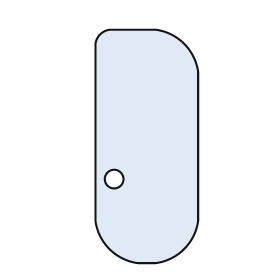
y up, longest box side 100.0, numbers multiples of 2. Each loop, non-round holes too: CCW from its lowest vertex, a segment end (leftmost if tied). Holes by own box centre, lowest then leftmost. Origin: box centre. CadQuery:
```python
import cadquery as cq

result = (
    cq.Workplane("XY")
    .moveTo(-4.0, -50.0)
    .lineTo(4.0, -50.0)
    .threePointArc((16.0, -44.0), (22.0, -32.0))
    .lineTo(22.0, 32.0)
    .threePointArc((16.0, 44.0), (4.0, 50.0))
    .lineTo(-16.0, 50.0)
    .threePointArc((-20.0, 48.0), (-22.0, 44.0))
    .lineTo(-22.0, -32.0)
    .threePointArc((-16.0, -44.0), (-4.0, -50.0))
    .close()
    .moveTo(-14.0, -14.0)
    .circle(4.0)
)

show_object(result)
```